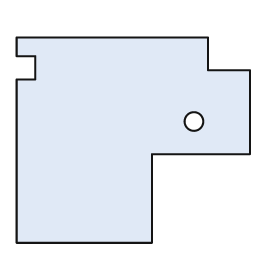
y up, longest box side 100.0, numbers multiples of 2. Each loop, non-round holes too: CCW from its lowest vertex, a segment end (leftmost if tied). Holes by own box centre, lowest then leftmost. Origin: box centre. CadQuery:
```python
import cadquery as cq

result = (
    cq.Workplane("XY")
    .moveTo(-50.0, -44.0)
    .lineTo(8.0, -44.0)
    .lineTo(8.0, -6.0)
    .lineTo(50.0, -6.0)
    .lineTo(50.0, 30.0)
    .lineTo(32.0, 30.0)
    .lineTo(32.0, 44.0)
    .lineTo(-50.0, 44.0)
    .lineTo(-50.0, 36.0)
    .lineTo(-42.0, 36.0)
    .lineTo(-42.0, 26.0)
    .lineTo(-50.0, 26.0)
    .close()
    .moveTo(26.0, 8.0)
    .circle(4.0)
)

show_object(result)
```